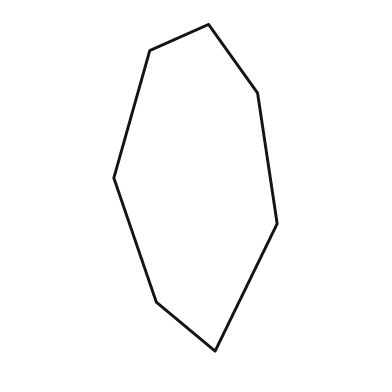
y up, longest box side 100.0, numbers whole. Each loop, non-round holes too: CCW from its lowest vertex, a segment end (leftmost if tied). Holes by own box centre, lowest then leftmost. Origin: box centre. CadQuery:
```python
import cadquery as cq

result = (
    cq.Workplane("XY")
    .moveTo(6.0, -50.0)
    .lineTo(25.0, -11.0)
    .lineTo(19.0, 29.0)
    .lineTo(4.0, 50.0)
    .lineTo(-14.0, 42.0)
    .lineTo(-25.0, 3.0)
    .lineTo(-12.0, -35.0)
    .close()
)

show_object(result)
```